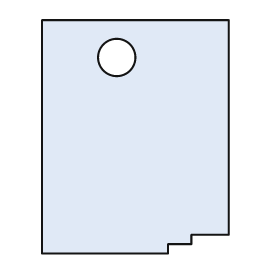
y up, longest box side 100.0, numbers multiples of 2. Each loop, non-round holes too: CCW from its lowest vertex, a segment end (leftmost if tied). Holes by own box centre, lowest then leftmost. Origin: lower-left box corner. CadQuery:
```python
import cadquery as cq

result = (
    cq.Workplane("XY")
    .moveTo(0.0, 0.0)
    .lineTo(54.0, 0.0)
    .lineTo(54.0, 4.0)
    .lineTo(64.0, 4.0)
    .lineTo(64.0, 8.0)
    .lineTo(80.0, 8.0)
    .lineTo(80.0, 100.0)
    .lineTo(0.0, 100.0)
    .close()
    .moveTo(32.0, 84.0)
    .circle(8.0)
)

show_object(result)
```